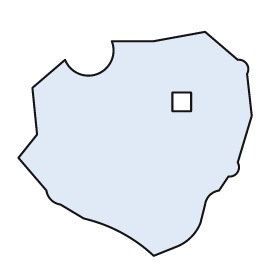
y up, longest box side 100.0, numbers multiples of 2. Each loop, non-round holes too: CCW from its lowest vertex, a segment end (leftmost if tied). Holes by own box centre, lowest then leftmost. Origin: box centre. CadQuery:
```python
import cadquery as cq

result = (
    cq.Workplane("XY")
    .moveTo(8.0, -48.0)
    .lineTo(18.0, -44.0)
    .threePointArc((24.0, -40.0), (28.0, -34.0))
    .lineTo(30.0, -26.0)
    .threePointArc((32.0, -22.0), (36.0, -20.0))
    .lineTo(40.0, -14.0)
    .threePointArc((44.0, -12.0), (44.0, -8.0))
    .lineTo(50.0, 12.0)
    .lineTo(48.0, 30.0)
    .threePointArc((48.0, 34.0), (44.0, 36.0))
    .lineTo(30.0, 48.0)
    .lineTo(8.0, 44.0)
    .lineTo(-10.0, 44.0)
    .threePointArc((-16.0, 30.0), (-30.0, 36.0))
    .lineTo(-44.0, 24.0)
    .lineTo(-42.0, 4.0)
    .lineTo(-50.0, -6.0)
    .lineTo(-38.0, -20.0)
    .threePointArc((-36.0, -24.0), (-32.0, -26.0))
    .lineTo(-22.0, -32.0)
    .threePointArc((-6.0, -38.0), (8.0, -48.0))
    .close()
    .moveTo(16.0, 14.0)
    .lineTo(24.0, 14.0)
    .lineTo(24.0, 22.0)
    .lineTo(16.0, 22.0)
    .close()
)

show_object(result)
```